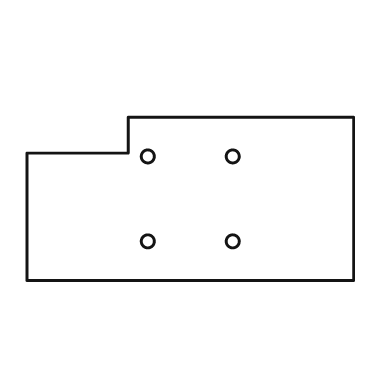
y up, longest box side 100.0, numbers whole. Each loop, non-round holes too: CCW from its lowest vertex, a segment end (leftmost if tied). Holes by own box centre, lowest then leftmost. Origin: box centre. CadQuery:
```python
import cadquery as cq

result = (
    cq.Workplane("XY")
    .moveTo(-50.0, -25.0)
    .lineTo(50.0, -25.0)
    .lineTo(50.0, 25.0)
    .lineTo(-19.0, 25.0)
    .lineTo(-19.0, 14.0)
    .lineTo(-50.0, 14.0)
    .close()
    .moveTo(-13.0, -13.0)
    .circle(2.0)
    .moveTo(13.0, -13.0)
    .circle(2.0)
    .moveTo(-13.0, 13.0)
    .circle(2.0)
    .moveTo(13.0, 13.0)
    .circle(2.0)
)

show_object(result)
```